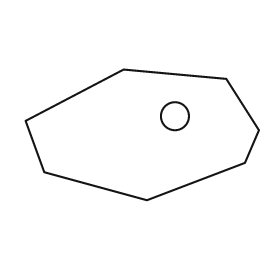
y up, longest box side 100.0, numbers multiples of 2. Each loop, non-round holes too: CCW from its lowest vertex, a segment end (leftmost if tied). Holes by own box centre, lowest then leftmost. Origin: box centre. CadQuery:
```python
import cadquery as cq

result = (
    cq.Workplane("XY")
    .moveTo(2.0, -28.0)
    .lineTo(44.0, -12.0)
    .lineTo(50.0, 2.0)
    .lineTo(36.0, 24.0)
    .lineTo(-8.0, 28.0)
    .lineTo(-50.0, 6.0)
    .lineTo(-42.0, -16.0)
    .close()
    .moveTo(14.0, 8.0)
    .circle(6.0)
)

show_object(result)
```